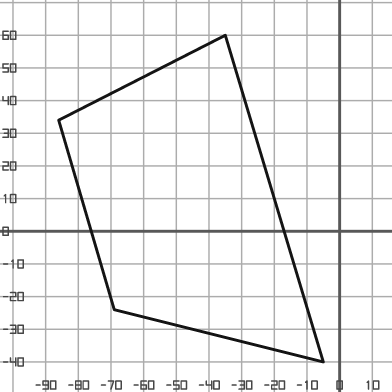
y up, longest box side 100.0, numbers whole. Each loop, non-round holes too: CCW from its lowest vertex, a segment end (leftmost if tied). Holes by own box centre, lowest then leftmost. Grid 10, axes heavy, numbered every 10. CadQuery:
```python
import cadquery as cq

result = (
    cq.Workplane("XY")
    .moveTo(-5.0, -40.0)
    .lineTo(-35.0, 60.0)
    .lineTo(-86.0, 34.0)
    .lineTo(-69.0, -24.0)
    .close()
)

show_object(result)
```